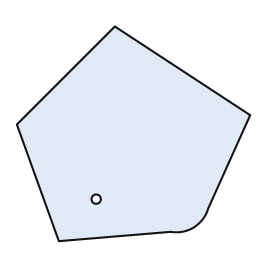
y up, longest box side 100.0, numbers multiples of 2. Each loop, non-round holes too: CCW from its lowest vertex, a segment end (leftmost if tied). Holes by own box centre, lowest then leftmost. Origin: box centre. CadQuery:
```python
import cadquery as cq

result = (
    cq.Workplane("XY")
    .moveTo(-32.0, -46.0)
    .lineTo(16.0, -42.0)
    .threePointArc((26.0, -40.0), (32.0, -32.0))
    .lineTo(50.0, 8.0)
    .lineTo(-8.0, 46.0)
    .lineTo(-50.0, 4.0)
    .close()
    .moveTo(-16.0, -28.0)
    .circle(2.0)
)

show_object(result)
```